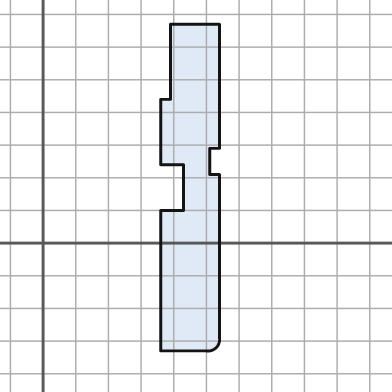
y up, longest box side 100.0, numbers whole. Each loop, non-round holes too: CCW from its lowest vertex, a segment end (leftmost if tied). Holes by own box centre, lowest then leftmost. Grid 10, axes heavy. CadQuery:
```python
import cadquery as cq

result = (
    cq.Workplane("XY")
    .moveTo(36.0, -33.0)
    .lineTo(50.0, -33.0)
    .threePointArc((53.0, -32.0), (54.0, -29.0))
    .lineTo(54.0, 21.0)
    .lineTo(51.0, 21.0)
    .lineTo(51.0, 29.0)
    .lineTo(54.0, 29.0)
    .lineTo(54.0, 67.0)
    .lineTo(39.0, 67.0)
    .lineTo(39.0, 44.0)
    .lineTo(36.0, 44.0)
    .lineTo(36.0, 24.0)
    .lineTo(43.0, 24.0)
    .lineTo(43.0, 10.0)
    .lineTo(36.0, 10.0)
    .close()
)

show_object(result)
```